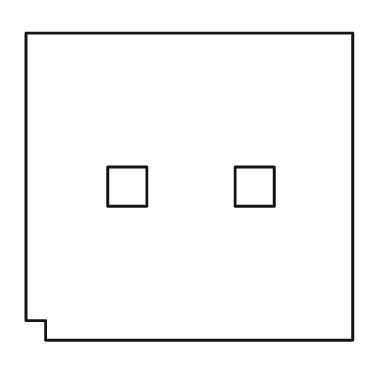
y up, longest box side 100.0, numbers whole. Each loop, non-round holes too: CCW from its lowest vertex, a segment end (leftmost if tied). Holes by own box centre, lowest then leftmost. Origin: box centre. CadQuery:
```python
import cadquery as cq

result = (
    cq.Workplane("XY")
    .moveTo(-44.0, -47.0)
    .lineTo(50.0, -47.0)
    .lineTo(50.0, 47.0)
    .lineTo(-50.0, 47.0)
    .lineTo(-50.0, -41.0)
    .lineTo(-44.0, -41.0)
    .close()
    .moveTo(-25.0, -6.0)
    .lineTo(-13.0, -6.0)
    .lineTo(-13.0, 6.0)
    .lineTo(-25.0, 6.0)
    .close()
    .moveTo(14.0, -6.0)
    .lineTo(26.0, -6.0)
    .lineTo(26.0, 6.0)
    .lineTo(14.0, 6.0)
    .close()
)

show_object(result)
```